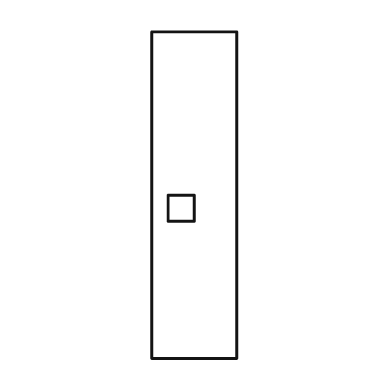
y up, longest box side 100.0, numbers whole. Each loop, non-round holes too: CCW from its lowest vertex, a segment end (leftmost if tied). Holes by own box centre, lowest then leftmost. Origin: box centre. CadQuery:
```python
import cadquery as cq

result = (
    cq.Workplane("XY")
    .moveTo(-13.0, -50.0)
    .lineTo(13.0, -50.0)
    .lineTo(13.0, 50.0)
    .lineTo(-13.0, 50.0)
    .close()
    .moveTo(-8.0, -8.0)
    .lineTo(0.0, -8.0)
    .lineTo(0.0, 0.0)
    .lineTo(-8.0, 0.0)
    .close()
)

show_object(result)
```